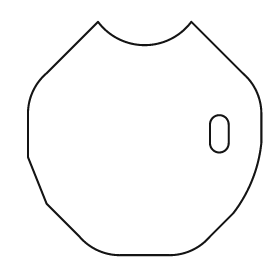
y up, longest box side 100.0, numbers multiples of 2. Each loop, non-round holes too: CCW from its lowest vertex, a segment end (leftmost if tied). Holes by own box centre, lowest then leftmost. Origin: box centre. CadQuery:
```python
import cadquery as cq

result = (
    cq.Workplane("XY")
    .moveTo(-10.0, -50.0)
    .lineTo(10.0, -50.0)
    .threePointArc((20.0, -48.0), (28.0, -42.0))
    .lineTo(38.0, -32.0)
    .threePointArc((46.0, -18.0), (50.0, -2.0))
    .lineTo(50.0, 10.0)
    .threePointArc((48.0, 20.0), (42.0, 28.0))
    .lineTo(20.0, 50.0)
    .threePointArc((0.0, 40.0), (-20.0, 50.0))
    .lineTo(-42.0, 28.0)
    .threePointArc((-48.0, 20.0), (-50.0, 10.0))
    .lineTo(-50.0, -8.0)
    .lineTo(-42.0, -28.0)
    .lineTo(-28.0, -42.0)
    .threePointArc((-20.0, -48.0), (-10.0, -50.0))
    .close()
    .moveTo(28.0, -2.0)
    .threePointArc((32.0, -6.0), (36.0, -2.0))
    .lineTo(36.0, 6.0)
    .threePointArc((32.0, 10.0), (28.0, 6.0))
    .close()
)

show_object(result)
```